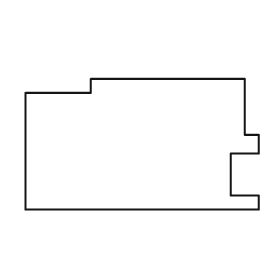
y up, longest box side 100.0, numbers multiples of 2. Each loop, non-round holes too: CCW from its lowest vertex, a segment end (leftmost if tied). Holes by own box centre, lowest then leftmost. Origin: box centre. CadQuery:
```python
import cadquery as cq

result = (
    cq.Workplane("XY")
    .moveTo(-50.0, -28.0)
    .lineTo(50.0, -28.0)
    .lineTo(50.0, -22.0)
    .lineTo(38.0, -22.0)
    .lineTo(38.0, -4.0)
    .lineTo(50.0, -4.0)
    .lineTo(50.0, 4.0)
    .lineTo(44.0, 4.0)
    .lineTo(44.0, 28.0)
    .lineTo(-22.0, 28.0)
    .lineTo(-22.0, 22.0)
    .lineTo(-50.0, 22.0)
    .close()
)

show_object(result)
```